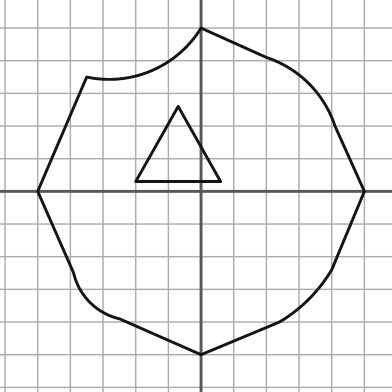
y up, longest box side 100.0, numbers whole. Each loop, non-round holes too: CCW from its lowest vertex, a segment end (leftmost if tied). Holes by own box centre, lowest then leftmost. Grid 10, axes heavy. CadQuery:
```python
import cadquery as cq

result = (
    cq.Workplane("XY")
    .moveTo(0.0, -50.0)
    .lineTo(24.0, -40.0)
    .threePointArc((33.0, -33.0), (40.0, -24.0))
    .lineTo(50.0, 0.0)
    .lineTo(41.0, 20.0)
    .threePointArc((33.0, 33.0), (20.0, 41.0))
    .lineTo(0.0, 50.0)
    .threePointArc((-15.0, 37.0), (-35.0, 35.0))
    .lineTo(-50.0, 0.0)
    .lineTo(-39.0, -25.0)
    .threePointArc((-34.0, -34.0), (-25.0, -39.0))
    .close()
    .moveTo(-20.0, 3.0)
    .lineTo(6.0, 3.0)
    .lineTo(-7.0, 26.0)
    .close()
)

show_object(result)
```